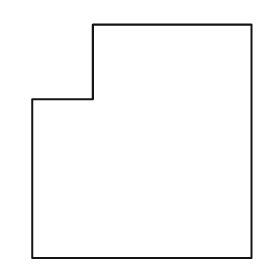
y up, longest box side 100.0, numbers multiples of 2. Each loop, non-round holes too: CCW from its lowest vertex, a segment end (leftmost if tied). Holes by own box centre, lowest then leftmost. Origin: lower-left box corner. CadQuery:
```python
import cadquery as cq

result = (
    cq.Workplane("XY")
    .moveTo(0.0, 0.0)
    .lineTo(94.0, 0.0)
    .lineTo(94.0, 100.0)
    .lineTo(26.0, 100.0)
    .lineTo(26.0, 68.0)
    .lineTo(0.0, 68.0)
    .close()
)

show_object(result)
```